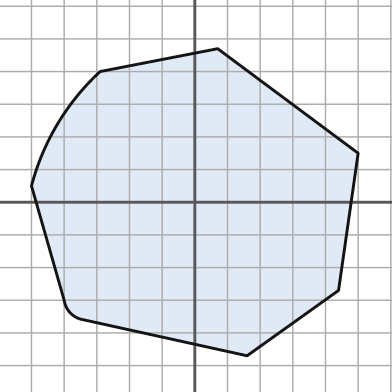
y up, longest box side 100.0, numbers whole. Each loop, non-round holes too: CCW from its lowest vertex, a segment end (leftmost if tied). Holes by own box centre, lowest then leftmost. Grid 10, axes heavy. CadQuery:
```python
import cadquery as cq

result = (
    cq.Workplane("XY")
    .moveTo(16.0, -47.0)
    .lineTo(44.0, -27.0)
    .lineTo(50.0, 15.0)
    .lineTo(7.0, 47.0)
    .lineTo(-29.0, 40.0)
    .threePointArc((-42.0, 24.0), (-50.0, 5.0))
    .lineTo(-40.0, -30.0)
    .threePointArc((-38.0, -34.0), (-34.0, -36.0))
    .close()
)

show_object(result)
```